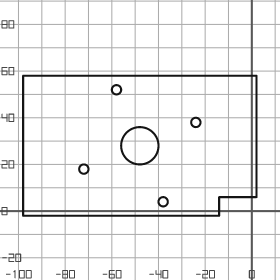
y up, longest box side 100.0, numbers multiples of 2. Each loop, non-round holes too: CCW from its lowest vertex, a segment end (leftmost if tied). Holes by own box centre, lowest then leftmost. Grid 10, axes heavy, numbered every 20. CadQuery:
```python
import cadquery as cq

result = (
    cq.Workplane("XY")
    .moveTo(-98.0, -2.0)
    .lineTo(-14.0, -2.0)
    .lineTo(-14.0, 6.0)
    .lineTo(2.0, 6.0)
    .lineTo(2.0, 58.0)
    .lineTo(-98.0, 58.0)
    .close()
    .moveTo(-38.0, 4.0)
    .circle(2.0)
    .moveTo(-72.0, 18.0)
    .circle(2.0)
    .moveTo(-48.0, 28.0)
    .circle(8.0)
    .moveTo(-24.0, 38.0)
    .circle(2.0)
    .moveTo(-58.0, 52.0)
    .circle(2.0)
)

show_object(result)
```